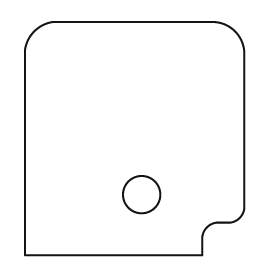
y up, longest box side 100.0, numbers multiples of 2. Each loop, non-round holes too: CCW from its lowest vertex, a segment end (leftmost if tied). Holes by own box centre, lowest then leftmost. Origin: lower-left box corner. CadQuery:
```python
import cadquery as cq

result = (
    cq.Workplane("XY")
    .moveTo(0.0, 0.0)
    .lineTo(76.0, 0.0)
    .lineTo(76.0, 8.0)
    .threePointArc((78.0, 12.0), (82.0, 14.0))
    .lineTo(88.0, 14.0)
    .threePointArc((92.0, 16.0), (94.0, 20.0))
    .lineTo(94.0, 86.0)
    .threePointArc((90.0, 96.0), (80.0, 100.0))
    .lineTo(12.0, 100.0)
    .threePointArc((4.0, 96.0), (0.0, 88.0))
    .close()
    .moveTo(50.0, 26.0)
    .circle(8.0)
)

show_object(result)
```